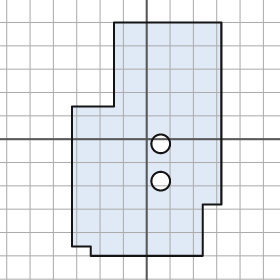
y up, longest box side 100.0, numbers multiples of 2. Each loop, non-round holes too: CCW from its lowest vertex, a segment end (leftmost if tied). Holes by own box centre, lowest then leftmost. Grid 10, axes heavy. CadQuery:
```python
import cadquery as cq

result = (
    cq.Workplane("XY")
    .moveTo(-24.0, -50.0)
    .lineTo(24.0, -50.0)
    .lineTo(24.0, -28.0)
    .lineTo(32.0, -28.0)
    .lineTo(32.0, 50.0)
    .lineTo(-14.0, 50.0)
    .lineTo(-14.0, 14.0)
    .lineTo(-32.0, 14.0)
    .lineTo(-32.0, -46.0)
    .lineTo(-24.0, -46.0)
    .close()
    .moveTo(6.0, -18.0)
    .circle(4.0)
    .moveTo(6.0, -2.0)
    .circle(4.0)
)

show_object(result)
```